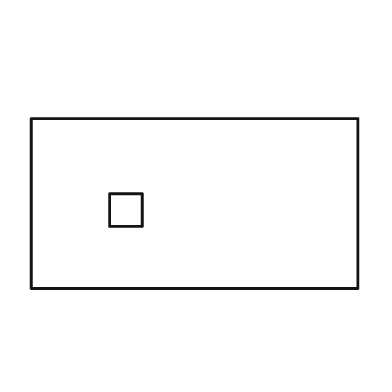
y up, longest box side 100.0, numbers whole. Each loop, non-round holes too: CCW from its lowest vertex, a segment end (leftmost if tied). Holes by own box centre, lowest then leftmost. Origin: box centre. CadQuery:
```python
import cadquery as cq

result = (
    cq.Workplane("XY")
    .moveTo(-50.0, -26.0)
    .lineTo(50.0, -26.0)
    .lineTo(50.0, 26.0)
    .lineTo(-50.0, 26.0)
    .close()
    .moveTo(-26.0, -7.0)
    .lineTo(-16.0, -7.0)
    .lineTo(-16.0, 3.0)
    .lineTo(-26.0, 3.0)
    .close()
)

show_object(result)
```